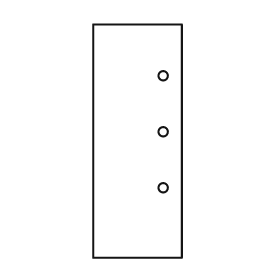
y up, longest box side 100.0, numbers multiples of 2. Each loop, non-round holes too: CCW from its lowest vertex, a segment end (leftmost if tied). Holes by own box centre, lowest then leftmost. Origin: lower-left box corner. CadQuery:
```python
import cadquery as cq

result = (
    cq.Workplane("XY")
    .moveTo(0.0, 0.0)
    .lineTo(38.0, 0.0)
    .lineTo(38.0, 100.0)
    .lineTo(0.0, 100.0)
    .close()
    .moveTo(30.0, 30.0)
    .circle(2.0)
    .moveTo(30.0, 54.0)
    .circle(2.0)
    .moveTo(30.0, 78.0)
    .circle(2.0)
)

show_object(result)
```